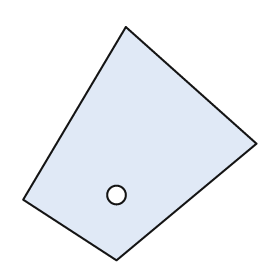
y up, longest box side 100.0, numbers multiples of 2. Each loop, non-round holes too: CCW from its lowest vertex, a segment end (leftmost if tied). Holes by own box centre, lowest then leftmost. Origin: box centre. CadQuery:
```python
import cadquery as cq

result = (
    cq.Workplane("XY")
    .moveTo(-10.0, -50.0)
    .lineTo(50.0, 0.0)
    .lineTo(-6.0, 50.0)
    .lineTo(-50.0, -24.0)
    .close()
    .moveTo(-10.0, -22.0)
    .circle(4.0)
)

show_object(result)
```